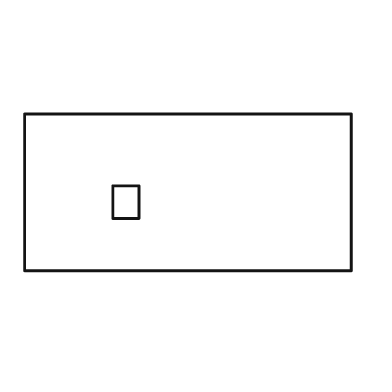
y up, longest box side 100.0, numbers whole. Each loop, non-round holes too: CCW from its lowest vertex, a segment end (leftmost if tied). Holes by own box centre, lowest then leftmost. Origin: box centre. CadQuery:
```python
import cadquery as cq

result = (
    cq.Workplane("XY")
    .moveTo(-50.0, -24.0)
    .lineTo(50.0, -24.0)
    .lineTo(50.0, 24.0)
    .lineTo(-50.0, 24.0)
    .close()
    .moveTo(-23.0, -8.0)
    .lineTo(-15.0, -8.0)
    .lineTo(-15.0, 2.0)
    .lineTo(-23.0, 2.0)
    .close()
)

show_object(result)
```